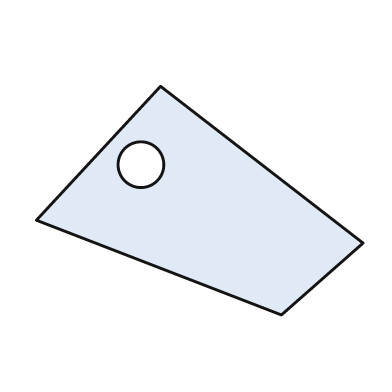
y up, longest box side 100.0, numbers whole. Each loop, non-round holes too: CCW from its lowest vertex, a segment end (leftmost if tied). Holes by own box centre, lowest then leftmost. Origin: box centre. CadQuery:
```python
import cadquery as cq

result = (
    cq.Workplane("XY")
    .moveTo(25.0, -35.0)
    .lineTo(50.0, -13.0)
    .lineTo(-12.0, 35.0)
    .lineTo(-50.0, -6.0)
    .close()
    .moveTo(-18.0, 11.0)
    .circle(7.0)
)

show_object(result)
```